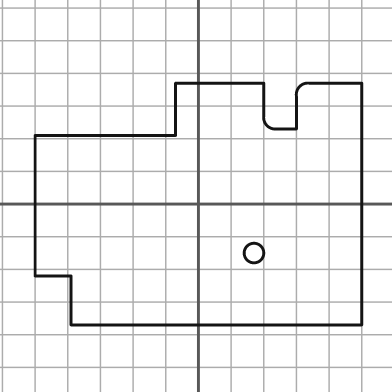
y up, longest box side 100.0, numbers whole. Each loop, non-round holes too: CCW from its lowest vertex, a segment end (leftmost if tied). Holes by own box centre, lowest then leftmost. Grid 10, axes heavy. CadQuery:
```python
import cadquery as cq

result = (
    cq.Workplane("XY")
    .moveTo(-39.0, -37.0)
    .lineTo(50.0, -37.0)
    .lineTo(50.0, 37.0)
    .lineTo(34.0, 37.0)
    .threePointArc((31.0, 36.0), (30.0, 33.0))
    .lineTo(30.0, 23.0)
    .lineTo(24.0, 23.0)
    .threePointArc((21.0, 24.0), (20.0, 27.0))
    .lineTo(20.0, 37.0)
    .lineTo(-7.0, 37.0)
    .lineTo(-7.0, 21.0)
    .lineTo(-50.0, 21.0)
    .lineTo(-50.0, -22.0)
    .lineTo(-39.0, -22.0)
    .close()
    .moveTo(17.0, -15.0)
    .circle(3.0)
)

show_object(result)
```